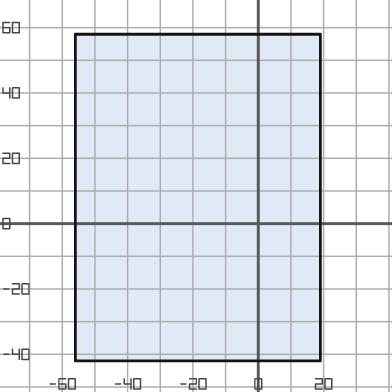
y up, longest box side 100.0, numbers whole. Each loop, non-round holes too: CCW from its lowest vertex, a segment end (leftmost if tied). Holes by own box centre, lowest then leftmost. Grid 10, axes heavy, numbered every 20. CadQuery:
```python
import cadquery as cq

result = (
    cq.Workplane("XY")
    .moveTo(-56.0, -42.0)
    .lineTo(19.0, -42.0)
    .lineTo(19.0, 58.0)
    .lineTo(-56.0, 58.0)
    .close()
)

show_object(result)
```